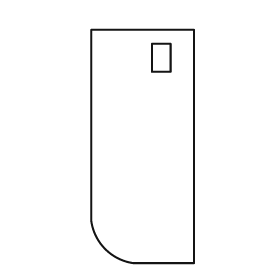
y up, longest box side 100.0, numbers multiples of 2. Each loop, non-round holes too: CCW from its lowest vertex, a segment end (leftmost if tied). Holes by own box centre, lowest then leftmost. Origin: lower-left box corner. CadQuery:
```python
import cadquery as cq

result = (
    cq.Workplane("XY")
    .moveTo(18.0, 0.0)
    .lineTo(44.0, 0.0)
    .lineTo(44.0, 100.0)
    .lineTo(0.0, 100.0)
    .lineTo(0.0, 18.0)
    .threePointArc((6.0, 6.0), (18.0, 0.0))
    .close()
    .moveTo(26.0, 82.0)
    .lineTo(34.0, 82.0)
    .lineTo(34.0, 94.0)
    .lineTo(26.0, 94.0)
    .close()
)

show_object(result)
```